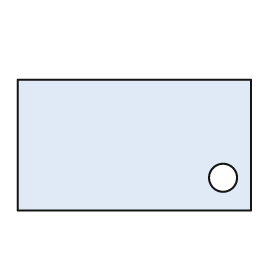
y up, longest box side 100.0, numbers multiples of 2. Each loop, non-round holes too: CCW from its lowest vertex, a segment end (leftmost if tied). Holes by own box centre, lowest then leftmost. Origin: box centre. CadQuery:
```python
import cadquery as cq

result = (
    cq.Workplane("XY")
    .moveTo(-50.0, -28.0)
    .lineTo(50.0, -28.0)
    .lineTo(50.0, 28.0)
    .lineTo(-50.0, 28.0)
    .close()
    .moveTo(38.0, -14.0)
    .circle(6.0)
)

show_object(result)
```